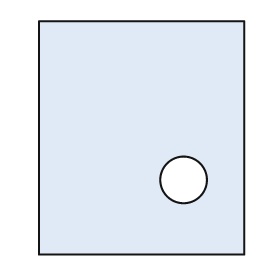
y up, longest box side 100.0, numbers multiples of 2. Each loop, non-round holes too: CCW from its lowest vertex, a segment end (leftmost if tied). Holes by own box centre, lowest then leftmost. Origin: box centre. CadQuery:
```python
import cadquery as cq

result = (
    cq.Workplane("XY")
    .moveTo(-44.0, -50.0)
    .lineTo(44.0, -50.0)
    .lineTo(44.0, 50.0)
    .lineTo(-44.0, 50.0)
    .close()
    .moveTo(18.0, -18.0)
    .circle(10.0)
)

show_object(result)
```